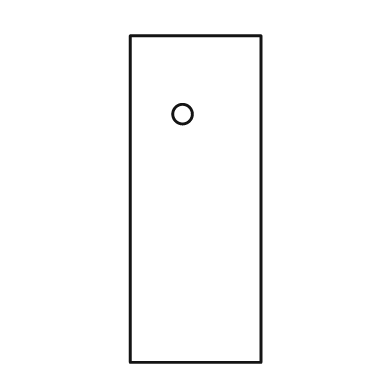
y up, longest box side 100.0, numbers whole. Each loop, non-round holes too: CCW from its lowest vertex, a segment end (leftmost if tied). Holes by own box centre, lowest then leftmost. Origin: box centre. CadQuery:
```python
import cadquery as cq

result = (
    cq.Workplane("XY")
    .moveTo(-20.0, -50.0)
    .lineTo(20.0, -50.0)
    .lineTo(20.0, 50.0)
    .lineTo(-20.0, 50.0)
    .close()
    .moveTo(-4.0, 26.0)
    .circle(3.0)
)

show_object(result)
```